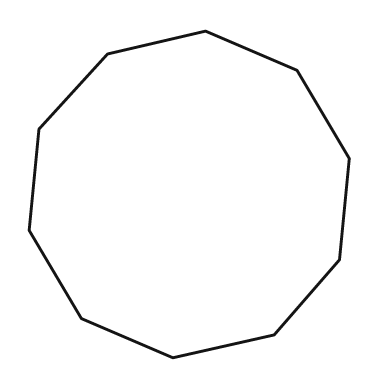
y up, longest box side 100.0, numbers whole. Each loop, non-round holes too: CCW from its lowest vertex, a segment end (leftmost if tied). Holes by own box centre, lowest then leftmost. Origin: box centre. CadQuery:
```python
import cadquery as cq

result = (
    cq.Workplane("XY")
    .moveTo(-5.0, -50.0)
    .lineTo(26.0, -43.0)
    .lineTo(46.0, -20.0)
    .lineTo(49.0, 11.0)
    .lineTo(33.0, 38.0)
    .lineTo(5.0, 50.0)
    .lineTo(-25.0, 43.0)
    .lineTo(-46.0, 20.0)
    .lineTo(-49.0, -11.0)
    .lineTo(-33.0, -38.0)
    .close()
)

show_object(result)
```